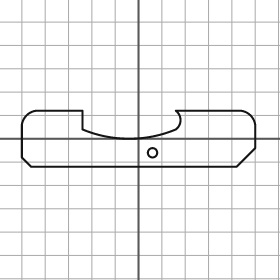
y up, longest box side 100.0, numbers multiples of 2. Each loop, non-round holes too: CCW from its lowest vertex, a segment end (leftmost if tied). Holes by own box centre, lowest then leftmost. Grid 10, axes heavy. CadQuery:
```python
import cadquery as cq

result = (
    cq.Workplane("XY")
    .moveTo(-46.0, -12.0)
    .lineTo(42.0, -12.0)
    .lineTo(50.0, -4.0)
    .lineTo(50.0, 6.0)
    .threePointArc((48.0, 10.0), (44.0, 12.0))
    .lineTo(16.0, 12.0)
    .threePointArc((18.0, 8.0), (16.0, 4.0))
    .threePointArc((-4.0, 0.0), (-24.0, 4.0))
    .lineTo(-24.0, 12.0)
    .lineTo(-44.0, 12.0)
    .threePointArc((-48.0, 10.0), (-50.0, 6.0))
    .lineTo(-50.0, -8.0)
    .close()
    .moveTo(6.0, -6.0)
    .circle(2.0)
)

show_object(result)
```